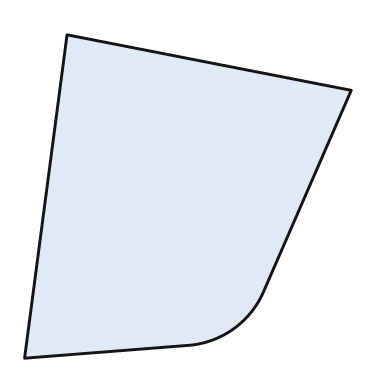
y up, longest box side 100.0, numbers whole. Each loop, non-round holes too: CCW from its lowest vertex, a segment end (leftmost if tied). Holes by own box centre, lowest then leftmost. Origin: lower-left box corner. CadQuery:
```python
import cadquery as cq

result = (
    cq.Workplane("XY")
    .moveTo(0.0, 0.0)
    .lineTo(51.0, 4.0)
    .threePointArc((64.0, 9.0), (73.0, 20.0))
    .lineTo(100.0, 82.0)
    .lineTo(13.0, 99.0)
    .close()
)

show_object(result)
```